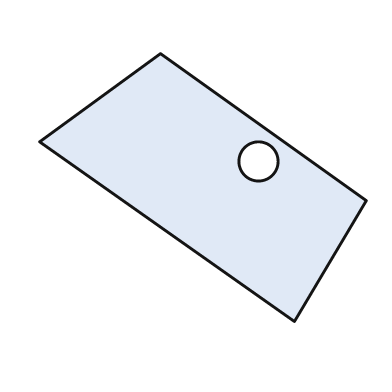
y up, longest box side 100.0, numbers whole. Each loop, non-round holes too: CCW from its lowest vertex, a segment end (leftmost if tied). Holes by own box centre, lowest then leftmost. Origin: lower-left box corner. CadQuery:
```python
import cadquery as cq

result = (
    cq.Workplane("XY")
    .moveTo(78.0, 0.0)
    .lineTo(100.0, 37.0)
    .lineTo(37.0, 82.0)
    .lineTo(0.0, 55.0)
    .close()
    .moveTo(67.0, 49.0)
    .circle(6.0)
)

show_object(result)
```